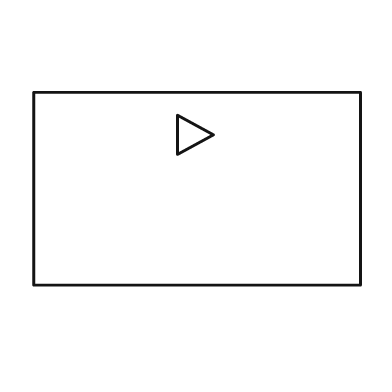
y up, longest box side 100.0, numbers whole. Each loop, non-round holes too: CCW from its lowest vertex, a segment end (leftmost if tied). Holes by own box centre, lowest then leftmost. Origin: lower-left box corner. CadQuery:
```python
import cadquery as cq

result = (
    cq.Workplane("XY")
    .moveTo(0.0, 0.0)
    .lineTo(100.0, 0.0)
    .lineTo(100.0, 59.0)
    .lineTo(0.0, 59.0)
    .close()
    .moveTo(44.0, 40.0)
    .lineTo(55.0, 46.0)
    .lineTo(44.0, 52.0)
    .close()
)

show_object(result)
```